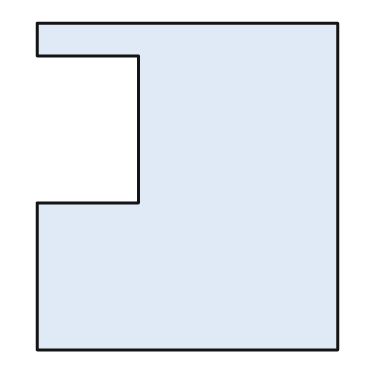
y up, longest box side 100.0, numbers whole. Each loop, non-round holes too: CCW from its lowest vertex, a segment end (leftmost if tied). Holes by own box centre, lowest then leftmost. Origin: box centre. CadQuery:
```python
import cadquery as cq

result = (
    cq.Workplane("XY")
    .moveTo(-46.0, -50.0)
    .lineTo(46.0, -50.0)
    .lineTo(46.0, 50.0)
    .lineTo(-46.0, 50.0)
    .lineTo(-46.0, 40.0)
    .lineTo(-15.0, 40.0)
    .lineTo(-15.0, -5.0)
    .lineTo(-46.0, -5.0)
    .close()
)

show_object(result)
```